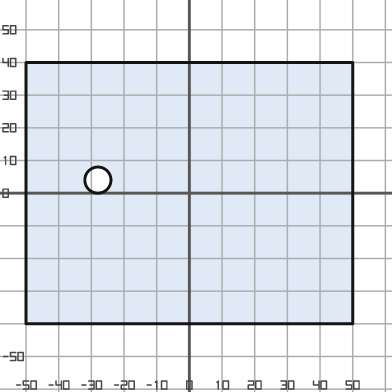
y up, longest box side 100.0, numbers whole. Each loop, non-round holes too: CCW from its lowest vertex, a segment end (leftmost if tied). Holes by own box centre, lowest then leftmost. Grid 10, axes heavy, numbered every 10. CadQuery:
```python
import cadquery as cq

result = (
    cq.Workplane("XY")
    .moveTo(-50.0, -40.0)
    .lineTo(50.0, -40.0)
    .lineTo(50.0, 40.0)
    .lineTo(-50.0, 40.0)
    .close()
    .moveTo(-28.0, 4.0)
    .circle(4.0)
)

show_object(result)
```